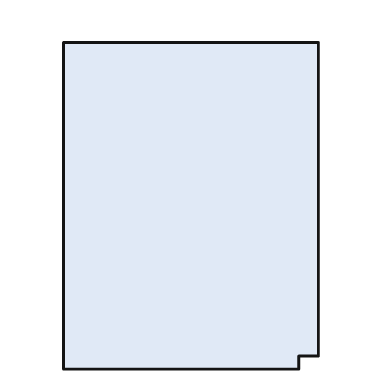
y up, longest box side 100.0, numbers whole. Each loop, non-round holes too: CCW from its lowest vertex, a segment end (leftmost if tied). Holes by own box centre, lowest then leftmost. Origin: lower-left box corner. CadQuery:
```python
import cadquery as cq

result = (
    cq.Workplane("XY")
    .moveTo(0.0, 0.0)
    .lineTo(72.0, 0.0)
    .lineTo(72.0, 4.0)
    .lineTo(78.0, 4.0)
    .lineTo(78.0, 100.0)
    .lineTo(0.0, 100.0)
    .close()
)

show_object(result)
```